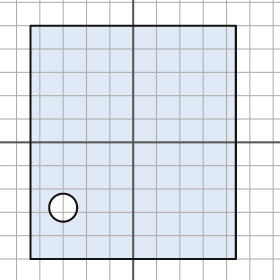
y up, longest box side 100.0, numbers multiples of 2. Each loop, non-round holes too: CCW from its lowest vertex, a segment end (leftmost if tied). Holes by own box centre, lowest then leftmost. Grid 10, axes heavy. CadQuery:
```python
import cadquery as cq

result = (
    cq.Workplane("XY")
    .moveTo(-44.0, -50.0)
    .lineTo(44.0, -50.0)
    .lineTo(44.0, 50.0)
    .lineTo(-44.0, 50.0)
    .close()
    .moveTo(-30.0, -28.0)
    .circle(6.0)
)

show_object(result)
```